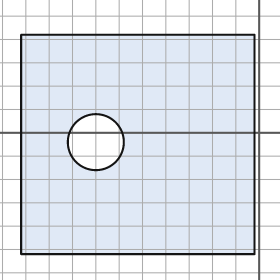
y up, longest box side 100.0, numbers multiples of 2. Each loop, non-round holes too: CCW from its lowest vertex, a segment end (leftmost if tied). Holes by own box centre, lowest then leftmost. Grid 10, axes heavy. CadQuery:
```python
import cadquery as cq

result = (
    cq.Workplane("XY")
    .moveTo(-102.0, -52.0)
    .lineTo(-2.0, -52.0)
    .lineTo(-2.0, 42.0)
    .lineTo(-102.0, 42.0)
    .close()
    .moveTo(-70.0, -4.0)
    .circle(12.0)
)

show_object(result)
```